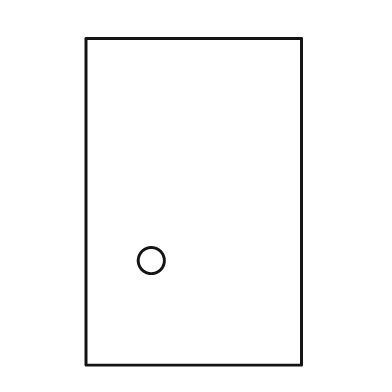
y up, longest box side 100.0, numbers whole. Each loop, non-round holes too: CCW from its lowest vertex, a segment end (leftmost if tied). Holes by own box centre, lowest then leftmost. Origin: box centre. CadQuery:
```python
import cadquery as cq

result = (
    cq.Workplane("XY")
    .moveTo(-33.0, -50.0)
    .lineTo(33.0, -50.0)
    .lineTo(33.0, 50.0)
    .lineTo(-33.0, 50.0)
    .close()
    .moveTo(-13.0, -18.0)
    .circle(4.0)
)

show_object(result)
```